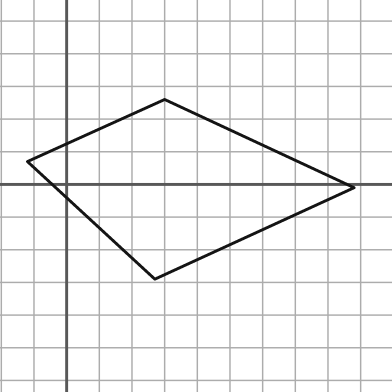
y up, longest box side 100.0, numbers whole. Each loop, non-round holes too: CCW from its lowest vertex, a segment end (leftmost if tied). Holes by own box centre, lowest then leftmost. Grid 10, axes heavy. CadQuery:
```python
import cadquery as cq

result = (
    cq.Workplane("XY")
    .moveTo(27.0, -29.0)
    .lineTo(88.0, -1.0)
    .lineTo(30.0, 26.0)
    .lineTo(-12.0, 7.0)
    .close()
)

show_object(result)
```